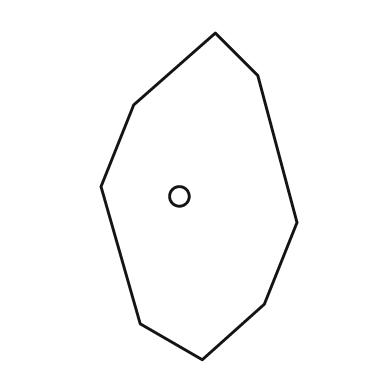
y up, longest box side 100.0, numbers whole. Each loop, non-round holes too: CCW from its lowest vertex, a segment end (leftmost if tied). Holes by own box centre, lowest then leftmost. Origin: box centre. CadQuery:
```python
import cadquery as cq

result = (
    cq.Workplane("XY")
    .moveTo(1.0, -50.0)
    .lineTo(20.0, -33.0)
    .lineTo(30.0, -8.0)
    .lineTo(18.0, 37.0)
    .lineTo(5.0, 50.0)
    .lineTo(-20.0, 28.0)
    .lineTo(-30.0, 3.0)
    .lineTo(-18.0, -39.0)
    .close()
    .moveTo(-6.0, 0.0)
    .circle(3.0)
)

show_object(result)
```